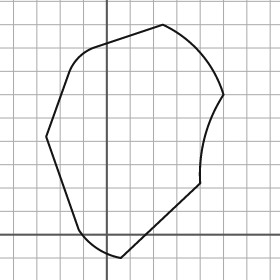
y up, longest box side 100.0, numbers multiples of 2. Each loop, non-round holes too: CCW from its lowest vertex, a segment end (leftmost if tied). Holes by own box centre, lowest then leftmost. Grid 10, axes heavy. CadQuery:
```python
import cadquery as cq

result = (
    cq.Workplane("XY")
    .moveTo(6.0, -10.0)
    .lineTo(40.0, 22.0)
    .threePointArc((42.0, 42.0), (50.0, 60.0))
    .threePointArc((40.0, 78.0), (24.0, 90.0))
    .lineTo(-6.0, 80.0)
    .threePointArc((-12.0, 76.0), (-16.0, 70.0))
    .lineTo(-26.0, 42.0)
    .lineTo(-12.0, 2.0)
    .threePointArc((-4.0, -6.0), (6.0, -10.0))
    .close()
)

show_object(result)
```